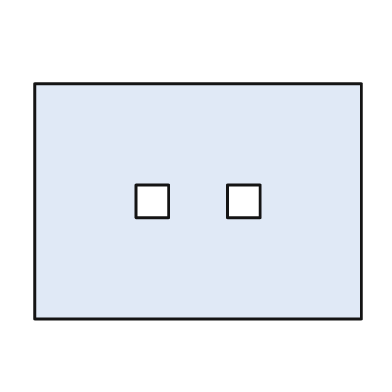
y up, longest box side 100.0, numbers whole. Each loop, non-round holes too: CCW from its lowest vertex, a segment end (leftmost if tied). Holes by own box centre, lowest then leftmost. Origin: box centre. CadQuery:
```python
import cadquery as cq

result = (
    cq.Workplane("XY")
    .moveTo(-50.0, -36.0)
    .lineTo(50.0, -36.0)
    .lineTo(50.0, 36.0)
    .lineTo(-50.0, 36.0)
    .close()
    .moveTo(-19.0, -5.0)
    .lineTo(-9.0, -5.0)
    .lineTo(-9.0, 5.0)
    .lineTo(-19.0, 5.0)
    .close()
    .moveTo(9.0, -5.0)
    .lineTo(19.0, -5.0)
    .lineTo(19.0, 5.0)
    .lineTo(9.0, 5.0)
    .close()
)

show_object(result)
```